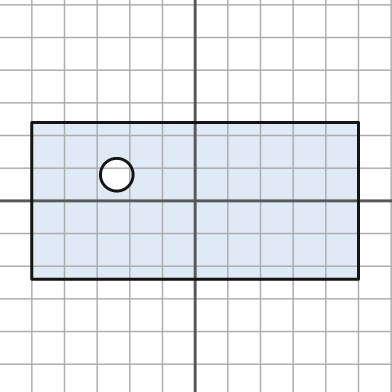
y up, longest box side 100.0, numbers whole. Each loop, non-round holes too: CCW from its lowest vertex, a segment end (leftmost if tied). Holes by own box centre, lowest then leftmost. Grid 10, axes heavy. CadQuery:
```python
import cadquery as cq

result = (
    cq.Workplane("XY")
    .moveTo(-50.0, -24.0)
    .lineTo(50.0, -24.0)
    .lineTo(50.0, 24.0)
    .lineTo(-50.0, 24.0)
    .close()
    .moveTo(-24.0, 8.0)
    .circle(5.0)
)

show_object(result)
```